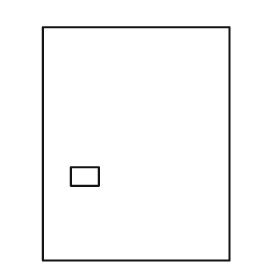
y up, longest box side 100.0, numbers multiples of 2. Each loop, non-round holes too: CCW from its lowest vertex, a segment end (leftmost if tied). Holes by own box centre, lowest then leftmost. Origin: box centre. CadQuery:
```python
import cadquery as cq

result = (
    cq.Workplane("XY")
    .moveTo(-40.0, -50.0)
    .lineTo(40.0, -50.0)
    .lineTo(40.0, 50.0)
    .lineTo(-40.0, 50.0)
    .close()
    .moveTo(-28.0, -18.0)
    .lineTo(-16.0, -18.0)
    .lineTo(-16.0, -10.0)
    .lineTo(-28.0, -10.0)
    .close()
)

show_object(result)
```